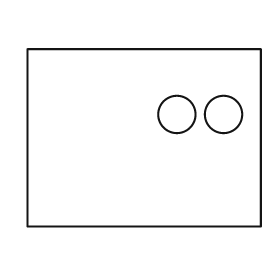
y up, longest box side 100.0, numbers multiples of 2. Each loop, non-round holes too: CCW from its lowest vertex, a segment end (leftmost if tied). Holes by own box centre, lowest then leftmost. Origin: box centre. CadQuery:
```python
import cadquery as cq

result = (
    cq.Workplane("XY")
    .moveTo(-50.0, -38.0)
    .lineTo(50.0, -38.0)
    .lineTo(50.0, 38.0)
    .lineTo(-50.0, 38.0)
    .close()
    .moveTo(14.0, 10.0)
    .circle(8.0)
    .moveTo(34.0, 10.0)
    .circle(8.0)
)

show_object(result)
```